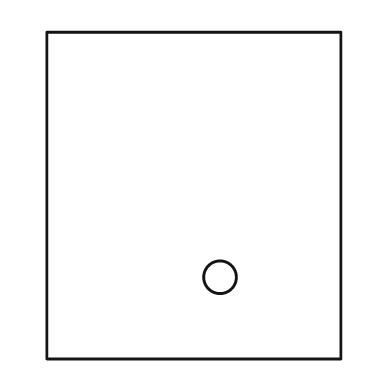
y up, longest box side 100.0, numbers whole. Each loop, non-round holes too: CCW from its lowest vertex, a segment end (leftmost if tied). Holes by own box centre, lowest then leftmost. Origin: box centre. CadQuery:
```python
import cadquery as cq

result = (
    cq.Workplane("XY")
    .moveTo(-45.0, -50.0)
    .lineTo(45.0, -50.0)
    .lineTo(45.0, 50.0)
    .lineTo(-45.0, 50.0)
    .close()
    .moveTo(8.0, -25.0)
    .circle(5.0)
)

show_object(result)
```